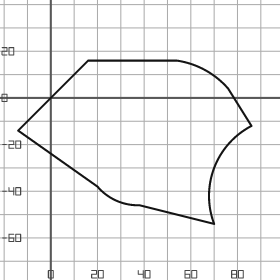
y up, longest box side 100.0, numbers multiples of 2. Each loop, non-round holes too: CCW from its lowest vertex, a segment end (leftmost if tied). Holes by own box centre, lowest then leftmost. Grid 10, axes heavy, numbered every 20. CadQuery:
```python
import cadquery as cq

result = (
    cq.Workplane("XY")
    .moveTo(70.0, -54.0)
    .threePointArc((70.0, -30.0), (86.0, -12.0))
    .lineTo(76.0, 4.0)
    .threePointArc((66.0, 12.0), (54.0, 16.0))
    .lineTo(16.0, 16.0)
    .lineTo(-14.0, -14.0)
    .lineTo(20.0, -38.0)
    .threePointArc((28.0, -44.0), (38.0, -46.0))
    .close()
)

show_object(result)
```